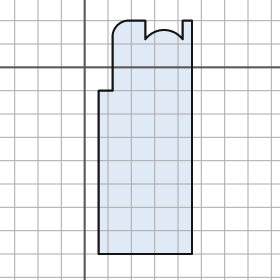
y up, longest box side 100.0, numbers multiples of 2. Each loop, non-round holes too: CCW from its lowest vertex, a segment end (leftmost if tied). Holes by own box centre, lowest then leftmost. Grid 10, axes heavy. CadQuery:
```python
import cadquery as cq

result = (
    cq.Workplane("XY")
    .moveTo(6.0, -80.0)
    .lineTo(46.0, -80.0)
    .lineTo(46.0, 20.0)
    .lineTo(42.0, 20.0)
    .lineTo(42.0, 12.0)
    .threePointArc((34.0, 16.0), (26.0, 12.0))
    .lineTo(26.0, 20.0)
    .lineTo(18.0, 20.0)
    .threePointArc((14.0, 18.0), (12.0, 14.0))
    .lineTo(12.0, -10.0)
    .lineTo(6.0, -10.0)
    .close()
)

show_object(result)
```